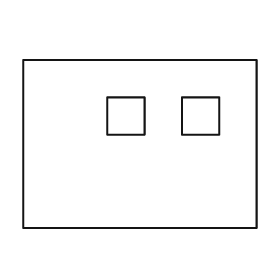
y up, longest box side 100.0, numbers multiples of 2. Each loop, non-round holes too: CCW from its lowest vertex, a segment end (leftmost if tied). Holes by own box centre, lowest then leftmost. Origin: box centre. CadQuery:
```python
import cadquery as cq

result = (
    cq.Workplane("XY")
    .moveTo(-50.0, -36.0)
    .lineTo(50.0, -36.0)
    .lineTo(50.0, 36.0)
    .lineTo(-50.0, 36.0)
    .close()
    .moveTo(-14.0, 4.0)
    .lineTo(2.0, 4.0)
    .lineTo(2.0, 20.0)
    .lineTo(-14.0, 20.0)
    .close()
    .moveTo(18.0, 4.0)
    .lineTo(34.0, 4.0)
    .lineTo(34.0, 20.0)
    .lineTo(18.0, 20.0)
    .close()
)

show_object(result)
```